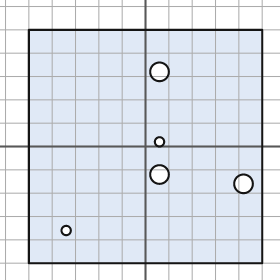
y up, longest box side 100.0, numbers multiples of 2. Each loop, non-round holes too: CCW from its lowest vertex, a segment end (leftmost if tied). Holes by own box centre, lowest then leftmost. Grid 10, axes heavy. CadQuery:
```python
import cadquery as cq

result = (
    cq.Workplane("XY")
    .moveTo(-50.0, -50.0)
    .lineTo(50.0, -50.0)
    .lineTo(50.0, 50.0)
    .lineTo(-50.0, 50.0)
    .close()
    .moveTo(-34.0, -36.0)
    .circle(2.0)
    .moveTo(42.0, -16.0)
    .circle(4.0)
    .moveTo(6.0, -12.0)
    .circle(4.0)
    .moveTo(6.0, 2.0)
    .circle(2.0)
    .moveTo(6.0, 32.0)
    .circle(4.0)
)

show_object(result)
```